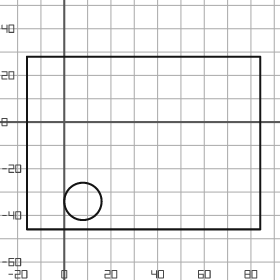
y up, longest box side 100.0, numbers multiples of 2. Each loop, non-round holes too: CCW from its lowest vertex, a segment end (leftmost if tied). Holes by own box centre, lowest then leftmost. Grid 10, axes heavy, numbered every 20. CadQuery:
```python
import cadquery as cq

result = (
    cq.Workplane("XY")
    .moveTo(-16.0, -46.0)
    .lineTo(84.0, -46.0)
    .lineTo(84.0, 28.0)
    .lineTo(-16.0, 28.0)
    .close()
    .moveTo(8.0, -34.0)
    .circle(8.0)
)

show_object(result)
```